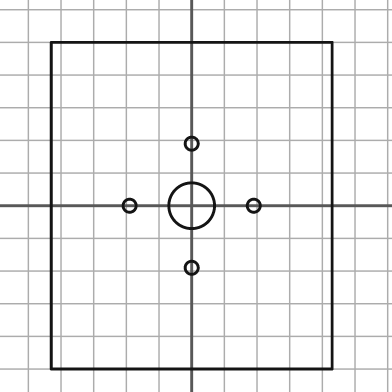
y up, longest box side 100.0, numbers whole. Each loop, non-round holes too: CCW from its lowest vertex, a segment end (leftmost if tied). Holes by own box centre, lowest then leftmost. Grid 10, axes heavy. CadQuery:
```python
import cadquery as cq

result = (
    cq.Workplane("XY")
    .moveTo(-43.0, -50.0)
    .lineTo(43.0, -50.0)
    .lineTo(43.0, 50.0)
    .lineTo(-43.0, 50.0)
    .close()
    .moveTo(0.0, -19.0)
    .circle(2.0)
    .moveTo(-19.0, 0.0)
    .circle(2.0)
    .moveTo(0.0, 0.0)
    .circle(7.0)
    .moveTo(19.0, 0.0)
    .circle(2.0)
    .moveTo(0.0, 19.0)
    .circle(2.0)
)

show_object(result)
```